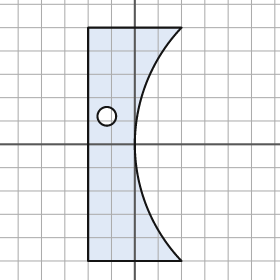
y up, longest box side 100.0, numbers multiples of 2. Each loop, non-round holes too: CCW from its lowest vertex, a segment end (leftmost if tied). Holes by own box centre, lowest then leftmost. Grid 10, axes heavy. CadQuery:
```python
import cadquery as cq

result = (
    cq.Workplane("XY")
    .moveTo(-20.0, -50.0)
    .lineTo(20.0, -50.0)
    .threePointArc((0.0, 0.0), (20.0, 50.0))
    .lineTo(-20.0, 50.0)
    .close()
    .moveTo(-12.0, 12.0)
    .circle(4.0)
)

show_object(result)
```